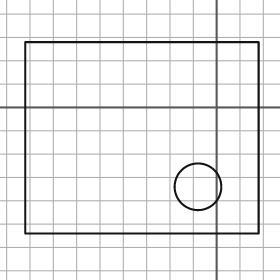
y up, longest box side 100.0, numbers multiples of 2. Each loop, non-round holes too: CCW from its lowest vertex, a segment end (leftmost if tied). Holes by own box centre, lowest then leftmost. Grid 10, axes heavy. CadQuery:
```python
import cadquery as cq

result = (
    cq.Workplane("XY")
    .moveTo(-82.0, -54.0)
    .lineTo(18.0, -54.0)
    .lineTo(18.0, 28.0)
    .lineTo(-82.0, 28.0)
    .close()
    .moveTo(-8.0, -34.0)
    .circle(10.0)
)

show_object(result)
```